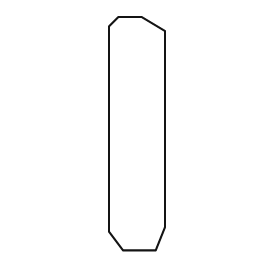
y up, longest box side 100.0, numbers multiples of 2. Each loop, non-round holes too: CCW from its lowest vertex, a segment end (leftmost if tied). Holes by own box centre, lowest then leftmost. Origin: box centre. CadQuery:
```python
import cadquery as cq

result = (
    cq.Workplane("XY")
    .moveTo(-6.0, -50.0)
    .lineTo(8.0, -50.0)
    .lineTo(12.0, -40.0)
    .lineTo(12.0, 44.0)
    .lineTo(2.0, 50.0)
    .lineTo(-8.0, 50.0)
    .lineTo(-12.0, 46.0)
    .lineTo(-12.0, -42.0)
    .close()
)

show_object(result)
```